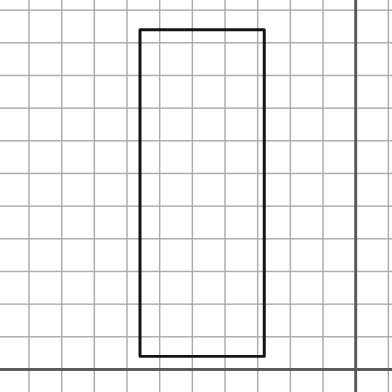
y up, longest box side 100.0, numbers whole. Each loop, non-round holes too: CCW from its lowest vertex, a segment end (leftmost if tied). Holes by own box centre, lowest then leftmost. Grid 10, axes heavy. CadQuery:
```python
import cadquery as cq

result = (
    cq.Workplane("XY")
    .moveTo(-66.0, 4.0)
    .lineTo(-28.0, 4.0)
    .lineTo(-28.0, 104.0)
    .lineTo(-66.0, 104.0)
    .close()
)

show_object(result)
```